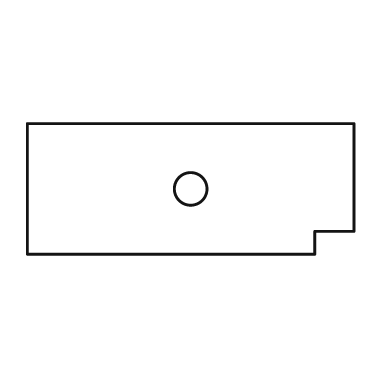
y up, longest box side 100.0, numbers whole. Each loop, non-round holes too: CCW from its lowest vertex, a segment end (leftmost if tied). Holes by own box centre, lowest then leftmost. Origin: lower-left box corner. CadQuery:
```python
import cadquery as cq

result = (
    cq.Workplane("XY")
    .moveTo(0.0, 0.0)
    .lineTo(88.0, 0.0)
    .lineTo(88.0, 7.0)
    .lineTo(100.0, 7.0)
    .lineTo(100.0, 40.0)
    .lineTo(0.0, 40.0)
    .close()
    .moveTo(50.0, 20.0)
    .circle(5.0)
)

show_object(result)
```